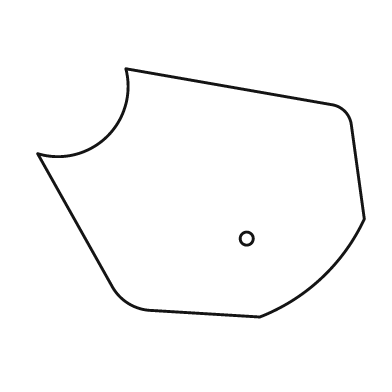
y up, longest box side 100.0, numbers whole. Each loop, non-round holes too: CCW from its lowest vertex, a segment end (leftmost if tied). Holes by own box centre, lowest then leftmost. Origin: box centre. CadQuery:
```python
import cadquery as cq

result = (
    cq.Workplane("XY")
    .moveTo(18.0, -38.0)
    .threePointArc((37.0, -26.0), (50.0, -8.0))
    .lineTo(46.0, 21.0)
    .threePointArc((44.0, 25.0), (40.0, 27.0))
    .lineTo(-23.0, 38.0)
    .threePointArc((-29.0, 17.0), (-50.0, 12.0))
    .lineTo(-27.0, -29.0)
    .threePointArc((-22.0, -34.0), (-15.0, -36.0))
    .close()
    .moveTo(14.0, -14.0)
    .circle(2.0)
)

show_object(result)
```